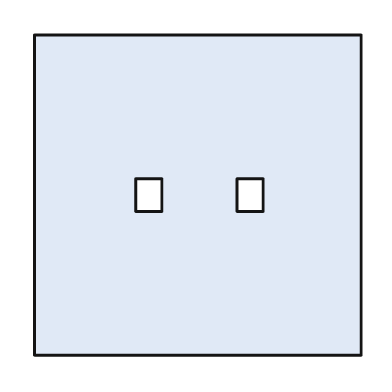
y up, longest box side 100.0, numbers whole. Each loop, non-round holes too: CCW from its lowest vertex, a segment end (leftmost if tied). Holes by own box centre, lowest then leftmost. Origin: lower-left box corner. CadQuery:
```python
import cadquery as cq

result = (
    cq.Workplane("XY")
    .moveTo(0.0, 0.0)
    .lineTo(100.0, 0.0)
    .lineTo(100.0, 98.0)
    .lineTo(0.0, 98.0)
    .close()
    .moveTo(31.0, 44.0)
    .lineTo(39.0, 44.0)
    .lineTo(39.0, 54.0)
    .lineTo(31.0, 54.0)
    .close()
    .moveTo(62.0, 44.0)
    .lineTo(70.0, 44.0)
    .lineTo(70.0, 54.0)
    .lineTo(62.0, 54.0)
    .close()
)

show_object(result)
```